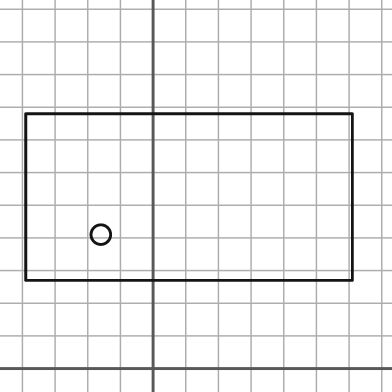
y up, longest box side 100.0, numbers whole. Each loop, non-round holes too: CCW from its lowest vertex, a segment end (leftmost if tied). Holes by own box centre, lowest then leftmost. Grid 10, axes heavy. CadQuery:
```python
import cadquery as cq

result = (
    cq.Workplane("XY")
    .moveTo(-39.0, 27.0)
    .lineTo(61.0, 27.0)
    .lineTo(61.0, 78.0)
    .lineTo(-39.0, 78.0)
    .close()
    .moveTo(-16.0, 41.0)
    .circle(3.0)
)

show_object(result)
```